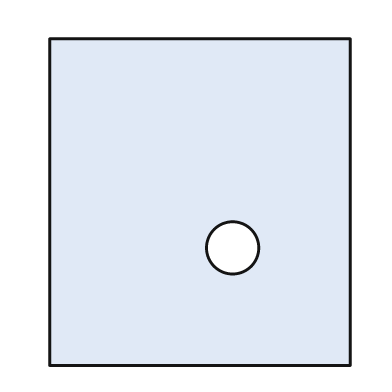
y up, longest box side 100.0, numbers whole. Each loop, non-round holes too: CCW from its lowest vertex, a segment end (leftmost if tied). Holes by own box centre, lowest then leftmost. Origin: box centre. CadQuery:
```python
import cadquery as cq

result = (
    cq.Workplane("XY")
    .moveTo(-46.0, -50.0)
    .lineTo(46.0, -50.0)
    .lineTo(46.0, 50.0)
    .lineTo(-46.0, 50.0)
    .close()
    .moveTo(10.0, -14.0)
    .circle(8.0)
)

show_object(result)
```